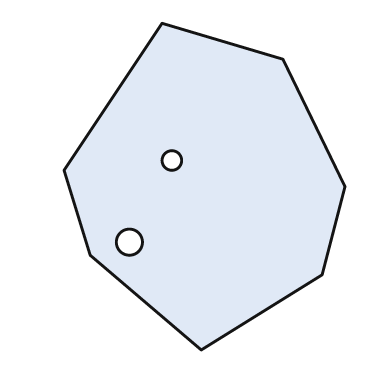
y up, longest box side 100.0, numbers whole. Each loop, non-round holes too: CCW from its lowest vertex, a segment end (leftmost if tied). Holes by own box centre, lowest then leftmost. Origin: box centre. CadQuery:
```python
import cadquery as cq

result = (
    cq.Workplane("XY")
    .moveTo(-1.0, -50.0)
    .lineTo(36.0, -27.0)
    .lineTo(43.0, 0.0)
    .lineTo(24.0, 39.0)
    .lineTo(-13.0, 50.0)
    .lineTo(-43.0, 5.0)
    .lineTo(-35.0, -21.0)
    .close()
    .moveTo(-23.0, -17.0)
    .circle(4.0)
    .moveTo(-10.0, 8.0)
    .circle(3.0)
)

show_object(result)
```